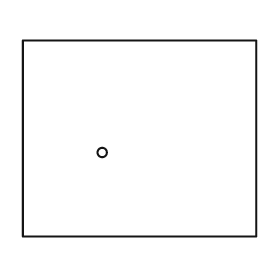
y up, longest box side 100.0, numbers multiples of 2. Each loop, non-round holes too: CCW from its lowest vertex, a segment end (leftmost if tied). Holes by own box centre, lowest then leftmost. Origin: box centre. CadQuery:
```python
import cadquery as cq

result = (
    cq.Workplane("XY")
    .moveTo(-50.0, -42.0)
    .lineTo(50.0, -42.0)
    .lineTo(50.0, 42.0)
    .lineTo(-50.0, 42.0)
    .close()
    .moveTo(-16.0, -6.0)
    .circle(2.0)
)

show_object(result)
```